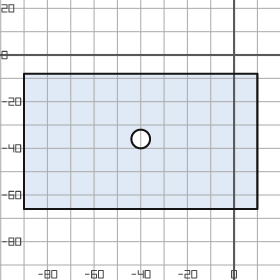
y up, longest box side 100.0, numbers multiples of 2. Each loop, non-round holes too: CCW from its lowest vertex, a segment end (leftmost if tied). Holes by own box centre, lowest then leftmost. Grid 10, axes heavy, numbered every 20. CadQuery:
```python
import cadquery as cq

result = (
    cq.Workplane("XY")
    .moveTo(-90.0, -66.0)
    .lineTo(10.0, -66.0)
    .lineTo(10.0, -8.0)
    .lineTo(-90.0, -8.0)
    .close()
    .moveTo(-40.0, -36.0)
    .circle(4.0)
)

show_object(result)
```